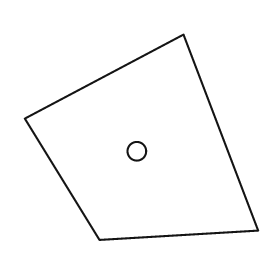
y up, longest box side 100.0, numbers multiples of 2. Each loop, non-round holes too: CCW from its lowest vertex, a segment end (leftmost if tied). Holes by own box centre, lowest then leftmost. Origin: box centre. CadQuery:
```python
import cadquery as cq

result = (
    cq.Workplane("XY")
    .moveTo(-18.0, -44.0)
    .lineTo(50.0, -40.0)
    .lineTo(18.0, 44.0)
    .lineTo(-50.0, 8.0)
    .close()
    .moveTo(-2.0, -6.0)
    .circle(4.0)
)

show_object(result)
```